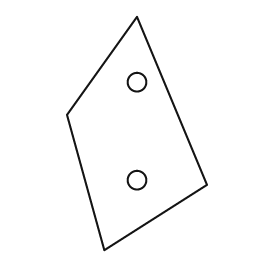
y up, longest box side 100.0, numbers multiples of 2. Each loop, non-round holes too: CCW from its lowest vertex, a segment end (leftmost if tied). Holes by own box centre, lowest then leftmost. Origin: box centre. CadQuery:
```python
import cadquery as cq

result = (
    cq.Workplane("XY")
    .moveTo(-14.0, -50.0)
    .lineTo(30.0, -22.0)
    .lineTo(0.0, 50.0)
    .lineTo(-30.0, 8.0)
    .close()
    .moveTo(0.0, -20.0)
    .circle(4.0)
    .moveTo(0.0, 22.0)
    .circle(4.0)
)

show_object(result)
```